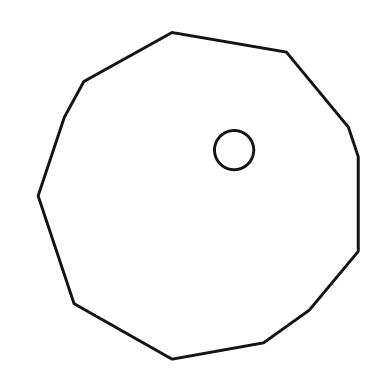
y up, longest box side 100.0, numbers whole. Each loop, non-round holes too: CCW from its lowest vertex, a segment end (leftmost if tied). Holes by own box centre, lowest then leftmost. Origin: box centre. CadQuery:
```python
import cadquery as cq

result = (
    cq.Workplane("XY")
    .moveTo(-8.0, -50.0)
    .lineTo(20.0, -45.0)
    .lineTo(34.0, -35.0)
    .lineTo(49.0, -17.0)
    .lineTo(49.0, 12.0)
    .lineTo(46.0, 21.0)
    .lineTo(27.0, 44.0)
    .lineTo(-8.0, 50.0)
    .lineTo(-35.0, 35.0)
    .lineTo(-41.0, 24.0)
    .lineTo(-49.0, 0.0)
    .lineTo(-38.0, -33.0)
    .close()
    .moveTo(11.0, 14.0)
    .circle(6.0)
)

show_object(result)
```